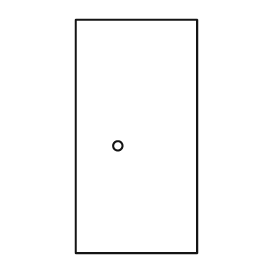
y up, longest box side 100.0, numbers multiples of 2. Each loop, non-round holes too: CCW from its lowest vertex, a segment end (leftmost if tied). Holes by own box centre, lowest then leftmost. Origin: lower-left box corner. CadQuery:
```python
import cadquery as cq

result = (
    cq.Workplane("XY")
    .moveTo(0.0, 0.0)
    .lineTo(52.0, 0.0)
    .lineTo(52.0, 100.0)
    .lineTo(0.0, 100.0)
    .close()
    .moveTo(18.0, 46.0)
    .circle(2.0)
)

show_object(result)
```